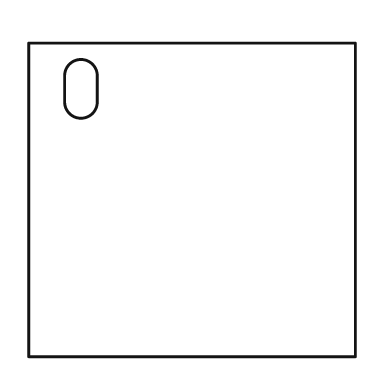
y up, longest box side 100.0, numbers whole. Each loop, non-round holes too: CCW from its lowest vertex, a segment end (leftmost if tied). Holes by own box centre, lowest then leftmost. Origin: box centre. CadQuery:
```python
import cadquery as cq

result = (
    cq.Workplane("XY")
    .moveTo(-50.0, -48.0)
    .lineTo(50.0, -48.0)
    .lineTo(50.0, 48.0)
    .lineTo(-50.0, 48.0)
    .close()
    .moveTo(-39.0, 30.0)
    .threePointArc((-34.0, 25.0), (-29.0, 30.0))
    .lineTo(-29.0, 38.0)
    .threePointArc((-34.0, 43.0), (-39.0, 38.0))
    .close()
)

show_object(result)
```